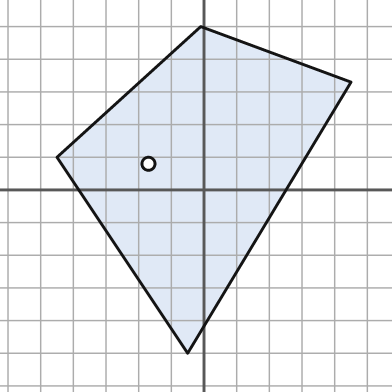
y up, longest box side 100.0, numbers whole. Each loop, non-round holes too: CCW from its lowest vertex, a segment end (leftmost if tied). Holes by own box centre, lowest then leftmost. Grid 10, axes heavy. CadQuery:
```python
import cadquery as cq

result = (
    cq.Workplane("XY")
    .moveTo(-5.0, -50.0)
    .lineTo(45.0, 33.0)
    .lineTo(-1.0, 50.0)
    .lineTo(-45.0, 10.0)
    .close()
    .moveTo(-17.0, 8.0)
    .circle(2.0)
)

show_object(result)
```